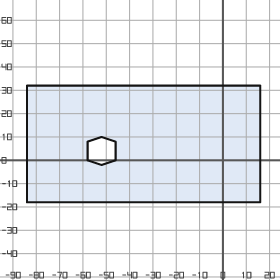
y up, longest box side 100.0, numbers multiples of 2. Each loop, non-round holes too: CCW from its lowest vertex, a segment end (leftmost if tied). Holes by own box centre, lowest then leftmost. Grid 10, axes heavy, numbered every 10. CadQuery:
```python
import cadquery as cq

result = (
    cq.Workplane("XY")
    .moveTo(-84.0, -18.0)
    .lineTo(16.0, -18.0)
    .lineTo(16.0, 32.0)
    .lineTo(-84.0, 32.0)
    .close()
    .moveTo(-52.0, -2.0)
    .lineTo(-46.0, 0.0)
    .lineTo(-46.0, 8.0)
    .lineTo(-52.0, 10.0)
    .lineTo(-58.0, 8.0)
    .lineTo(-58.0, 0.0)
    .close()
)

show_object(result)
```